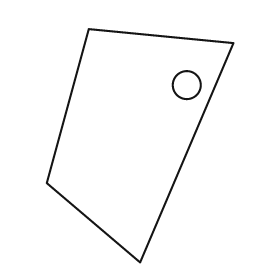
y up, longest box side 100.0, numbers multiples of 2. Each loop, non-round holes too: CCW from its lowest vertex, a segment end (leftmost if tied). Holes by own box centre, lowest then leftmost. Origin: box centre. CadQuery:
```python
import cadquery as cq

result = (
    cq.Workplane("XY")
    .moveTo(0.0, -50.0)
    .lineTo(40.0, 44.0)
    .lineTo(-22.0, 50.0)
    .lineTo(-40.0, -16.0)
    .close()
    .moveTo(20.0, 26.0)
    .circle(6.0)
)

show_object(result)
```